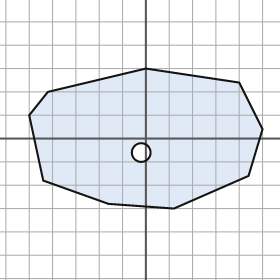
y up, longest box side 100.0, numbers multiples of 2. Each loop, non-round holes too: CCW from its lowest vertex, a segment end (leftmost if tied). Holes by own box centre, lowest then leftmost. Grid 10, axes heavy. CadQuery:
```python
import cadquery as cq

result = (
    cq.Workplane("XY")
    .moveTo(12.0, -30.0)
    .lineTo(44.0, -16.0)
    .lineTo(50.0, 4.0)
    .lineTo(40.0, 24.0)
    .lineTo(0.0, 30.0)
    .lineTo(-42.0, 20.0)
    .lineTo(-50.0, 10.0)
    .lineTo(-44.0, -18.0)
    .lineTo(-16.0, -28.0)
    .close()
    .moveTo(-2.0, -6.0)
    .circle(4.0)
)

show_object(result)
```